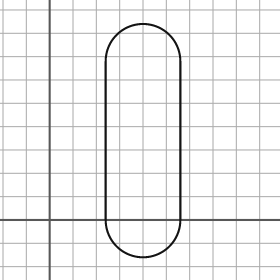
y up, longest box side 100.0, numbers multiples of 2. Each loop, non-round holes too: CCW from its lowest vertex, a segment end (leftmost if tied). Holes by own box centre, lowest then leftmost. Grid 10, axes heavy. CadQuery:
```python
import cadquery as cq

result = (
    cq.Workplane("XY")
    .moveTo(24.0, 0.0)
    .threePointArc((40.0, -16.0), (56.0, 0.0))
    .lineTo(56.0, 68.0)
    .threePointArc((40.0, 84.0), (24.0, 68.0))
    .close()
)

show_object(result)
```